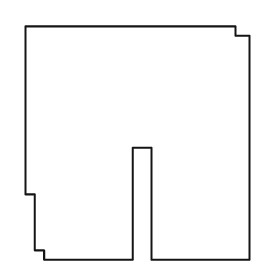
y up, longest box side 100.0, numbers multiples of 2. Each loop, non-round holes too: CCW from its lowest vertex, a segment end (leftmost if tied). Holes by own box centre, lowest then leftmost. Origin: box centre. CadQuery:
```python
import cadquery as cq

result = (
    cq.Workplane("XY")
    .moveTo(-40.0, -50.0)
    .lineTo(-2.0, -50.0)
    .lineTo(-2.0, -2.0)
    .lineTo(6.0, -2.0)
    .lineTo(6.0, -50.0)
    .lineTo(48.0, -50.0)
    .lineTo(48.0, 46.0)
    .lineTo(42.0, 46.0)
    .lineTo(42.0, 50.0)
    .lineTo(-48.0, 50.0)
    .lineTo(-48.0, -22.0)
    .lineTo(-44.0, -22.0)
    .lineTo(-44.0, -46.0)
    .lineTo(-40.0, -46.0)
    .close()
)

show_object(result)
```